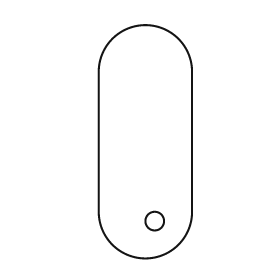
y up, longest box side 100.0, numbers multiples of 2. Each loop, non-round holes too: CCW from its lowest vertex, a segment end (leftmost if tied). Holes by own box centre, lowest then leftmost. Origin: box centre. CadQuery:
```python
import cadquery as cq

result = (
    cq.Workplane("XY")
    .moveTo(-20.0, -30.0)
    .threePointArc((0.0, -50.0), (20.0, -30.0))
    .lineTo(20.0, 30.0)
    .threePointArc((0.0, 50.0), (-20.0, 30.0))
    .close()
    .moveTo(4.0, -34.0)
    .circle(4.0)
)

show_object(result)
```